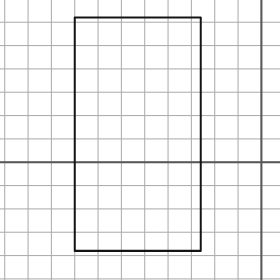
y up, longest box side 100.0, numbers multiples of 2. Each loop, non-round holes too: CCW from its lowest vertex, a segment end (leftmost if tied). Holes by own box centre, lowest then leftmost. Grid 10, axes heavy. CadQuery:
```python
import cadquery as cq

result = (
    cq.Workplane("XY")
    .moveTo(-80.0, -38.0)
    .lineTo(-26.0, -38.0)
    .lineTo(-26.0, 62.0)
    .lineTo(-80.0, 62.0)
    .close()
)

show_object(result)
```